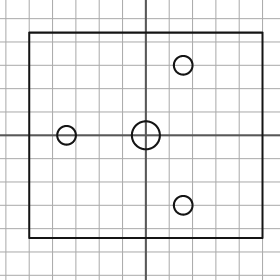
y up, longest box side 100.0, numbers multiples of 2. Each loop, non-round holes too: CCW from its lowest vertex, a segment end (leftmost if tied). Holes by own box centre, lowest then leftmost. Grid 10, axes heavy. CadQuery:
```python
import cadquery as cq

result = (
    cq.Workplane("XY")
    .moveTo(-50.0, -44.0)
    .lineTo(50.0, -44.0)
    .lineTo(50.0, 44.0)
    .lineTo(-50.0, 44.0)
    .close()
    .moveTo(16.0, -30.0)
    .circle(4.0)
    .moveTo(-34.0, 0.0)
    .circle(4.0)
    .moveTo(0.0, 0.0)
    .circle(6.0)
    .moveTo(16.0, 30.0)
    .circle(4.0)
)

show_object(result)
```